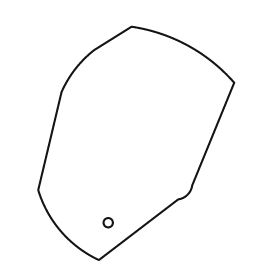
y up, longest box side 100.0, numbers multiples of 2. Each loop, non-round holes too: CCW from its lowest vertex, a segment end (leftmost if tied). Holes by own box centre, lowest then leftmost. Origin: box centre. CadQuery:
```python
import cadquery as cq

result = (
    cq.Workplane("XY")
    .moveTo(-16.0, -50.0)
    .lineTo(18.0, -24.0)
    .threePointArc((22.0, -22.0), (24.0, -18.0))
    .lineTo(42.0, 26.0)
    .threePointArc((22.0, 42.0), (-2.0, 50.0))
    .lineTo(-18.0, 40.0)
    .threePointArc((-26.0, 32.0), (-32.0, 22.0))
    .lineTo(-42.0, -20.0)
    .threePointArc((-32.0, -38.0), (-16.0, -50.0))
    .close()
    .moveTo(-12.0, -34.0)
    .circle(2.0)
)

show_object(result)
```